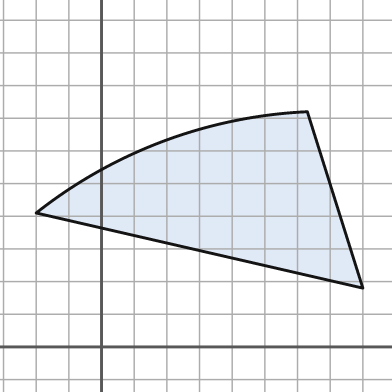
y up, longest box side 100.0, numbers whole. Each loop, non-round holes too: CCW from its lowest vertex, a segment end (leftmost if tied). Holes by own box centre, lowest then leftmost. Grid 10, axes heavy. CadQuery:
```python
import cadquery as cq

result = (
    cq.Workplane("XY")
    .moveTo(80.0, 18.0)
    .lineTo(63.0, 72.0)
    .threePointArc((19.0, 63.0), (-20.0, 41.0))
    .close()
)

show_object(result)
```